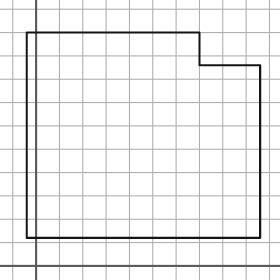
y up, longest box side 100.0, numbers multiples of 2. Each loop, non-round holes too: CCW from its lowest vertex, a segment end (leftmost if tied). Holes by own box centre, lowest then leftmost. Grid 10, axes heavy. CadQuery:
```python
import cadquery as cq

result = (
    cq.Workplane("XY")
    .moveTo(-4.0, 12.0)
    .lineTo(96.0, 12.0)
    .lineTo(96.0, 86.0)
    .lineTo(70.0, 86.0)
    .lineTo(70.0, 100.0)
    .lineTo(-4.0, 100.0)
    .close()
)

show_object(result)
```